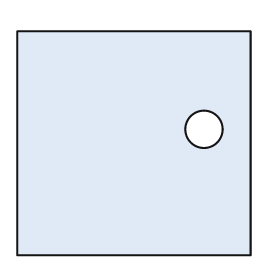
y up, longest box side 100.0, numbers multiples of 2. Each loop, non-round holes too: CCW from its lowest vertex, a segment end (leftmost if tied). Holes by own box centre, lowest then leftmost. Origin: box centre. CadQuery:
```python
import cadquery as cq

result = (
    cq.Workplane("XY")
    .moveTo(-50.0, -48.0)
    .lineTo(50.0, -48.0)
    .lineTo(50.0, 48.0)
    .lineTo(-50.0, 48.0)
    .close()
    .moveTo(30.0, 6.0)
    .circle(8.0)
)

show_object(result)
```